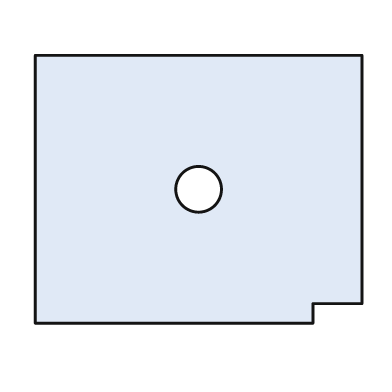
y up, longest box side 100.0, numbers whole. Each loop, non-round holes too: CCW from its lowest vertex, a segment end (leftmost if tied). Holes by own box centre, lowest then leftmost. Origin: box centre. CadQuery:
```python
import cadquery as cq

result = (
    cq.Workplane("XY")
    .moveTo(-50.0, -41.0)
    .lineTo(35.0, -41.0)
    .lineTo(35.0, -35.0)
    .lineTo(50.0, -35.0)
    .lineTo(50.0, 41.0)
    .lineTo(-50.0, 41.0)
    .close()
    .moveTo(0.0, 0.0)
    .circle(7.0)
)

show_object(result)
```